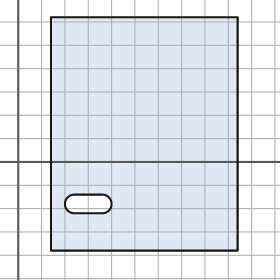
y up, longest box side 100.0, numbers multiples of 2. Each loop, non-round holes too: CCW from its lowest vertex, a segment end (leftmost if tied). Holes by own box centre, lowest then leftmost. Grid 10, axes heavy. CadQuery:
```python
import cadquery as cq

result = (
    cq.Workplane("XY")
    .moveTo(14.0, -38.0)
    .lineTo(94.0, -38.0)
    .lineTo(94.0, 62.0)
    .lineTo(14.0, 62.0)
    .close()
    .moveTo(24.0, -22.0)
    .lineTo(36.0, -22.0)
    .threePointArc((40.0, -18.0), (36.0, -14.0))
    .lineTo(24.0, -14.0)
    .threePointArc((20.0, -18.0), (24.0, -22.0))
    .close()
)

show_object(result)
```